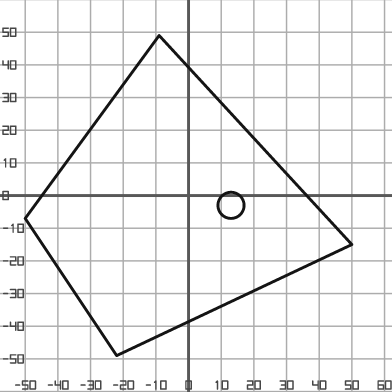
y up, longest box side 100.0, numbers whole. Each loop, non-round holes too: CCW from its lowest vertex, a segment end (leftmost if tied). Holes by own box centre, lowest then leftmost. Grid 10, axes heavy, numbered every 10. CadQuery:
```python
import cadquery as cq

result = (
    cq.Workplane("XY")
    .moveTo(-22.0, -49.0)
    .lineTo(50.0, -15.0)
    .lineTo(-9.0, 49.0)
    .lineTo(-50.0, -7.0)
    .close()
    .moveTo(13.0, -3.0)
    .circle(4.0)
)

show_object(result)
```